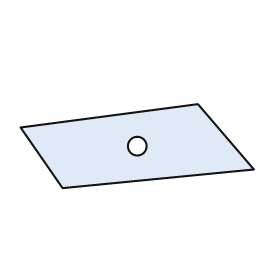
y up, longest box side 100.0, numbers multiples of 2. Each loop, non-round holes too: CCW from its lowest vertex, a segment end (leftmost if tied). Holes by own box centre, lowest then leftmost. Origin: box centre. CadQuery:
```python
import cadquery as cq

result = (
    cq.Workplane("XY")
    .moveTo(-32.0, -18.0)
    .lineTo(50.0, -10.0)
    .lineTo(26.0, 18.0)
    .lineTo(-50.0, 8.0)
    .close()
    .moveTo(0.0, 0.0)
    .circle(4.0)
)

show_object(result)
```